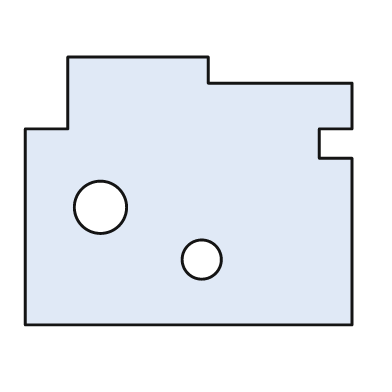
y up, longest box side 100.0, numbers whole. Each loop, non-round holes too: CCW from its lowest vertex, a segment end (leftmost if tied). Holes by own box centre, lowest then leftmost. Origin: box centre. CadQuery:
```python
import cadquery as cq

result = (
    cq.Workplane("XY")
    .moveTo(-50.0, -41.0)
    .lineTo(50.0, -41.0)
    .lineTo(50.0, 10.0)
    .lineTo(40.0, 10.0)
    .lineTo(40.0, 19.0)
    .lineTo(50.0, 19.0)
    .lineTo(50.0, 33.0)
    .lineTo(6.0, 33.0)
    .lineTo(6.0, 41.0)
    .lineTo(-37.0, 41.0)
    .lineTo(-37.0, 19.0)
    .lineTo(-50.0, 19.0)
    .close()
    .moveTo(4.0, -21.0)
    .circle(6.0)
    .moveTo(-27.0, -5.0)
    .circle(8.0)
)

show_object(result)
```